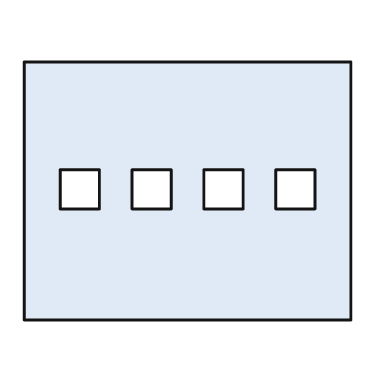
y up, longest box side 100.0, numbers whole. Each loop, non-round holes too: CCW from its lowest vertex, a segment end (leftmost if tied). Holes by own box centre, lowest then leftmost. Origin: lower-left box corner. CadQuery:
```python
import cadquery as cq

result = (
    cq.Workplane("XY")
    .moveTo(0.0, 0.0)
    .lineTo(100.0, 0.0)
    .lineTo(100.0, 79.0)
    .lineTo(0.0, 79.0)
    .close()
    .moveTo(11.0, 34.0)
    .lineTo(23.0, 34.0)
    .lineTo(23.0, 46.0)
    .lineTo(11.0, 46.0)
    .close()
    .moveTo(33.0, 34.0)
    .lineTo(45.0, 34.0)
    .lineTo(45.0, 46.0)
    .lineTo(33.0, 46.0)
    .close()
    .moveTo(55.0, 34.0)
    .lineTo(67.0, 34.0)
    .lineTo(67.0, 46.0)
    .lineTo(55.0, 46.0)
    .close()
    .moveTo(77.0, 34.0)
    .lineTo(89.0, 34.0)
    .lineTo(89.0, 46.0)
    .lineTo(77.0, 46.0)
    .close()
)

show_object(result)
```